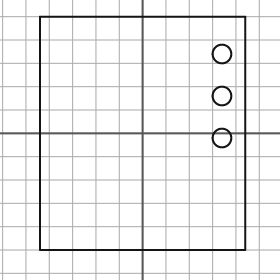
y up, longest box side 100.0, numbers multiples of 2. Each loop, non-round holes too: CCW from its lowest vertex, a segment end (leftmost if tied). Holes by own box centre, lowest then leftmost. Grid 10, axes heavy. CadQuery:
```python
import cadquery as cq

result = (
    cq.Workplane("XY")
    .moveTo(-44.0, -50.0)
    .lineTo(44.0, -50.0)
    .lineTo(44.0, 50.0)
    .lineTo(-44.0, 50.0)
    .close()
    .moveTo(34.0, -2.0)
    .circle(4.0)
    .moveTo(34.0, 16.0)
    .circle(4.0)
    .moveTo(34.0, 34.0)
    .circle(4.0)
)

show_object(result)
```